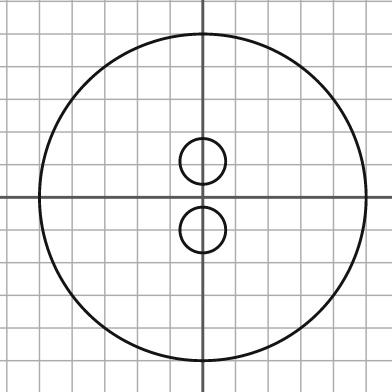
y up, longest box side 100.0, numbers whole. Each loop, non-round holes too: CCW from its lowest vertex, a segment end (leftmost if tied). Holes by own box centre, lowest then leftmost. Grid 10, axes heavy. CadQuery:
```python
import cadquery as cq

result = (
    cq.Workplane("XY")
    .moveTo(0.0, 0.0)
    .circle(50.0)
    .moveTo(0.0, -10.0)
    .circle(7.0)
    .moveTo(0.0, 11.0)
    .circle(7.0)
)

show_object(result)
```